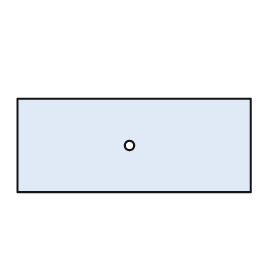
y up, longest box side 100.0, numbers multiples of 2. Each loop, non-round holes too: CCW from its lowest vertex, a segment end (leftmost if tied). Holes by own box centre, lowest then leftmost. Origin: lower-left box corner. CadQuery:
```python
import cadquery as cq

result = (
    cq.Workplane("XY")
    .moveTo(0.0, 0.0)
    .lineTo(100.0, 0.0)
    .lineTo(100.0, 40.0)
    .lineTo(0.0, 40.0)
    .close()
    .moveTo(48.0, 20.0)
    .circle(2.0)
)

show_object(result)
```